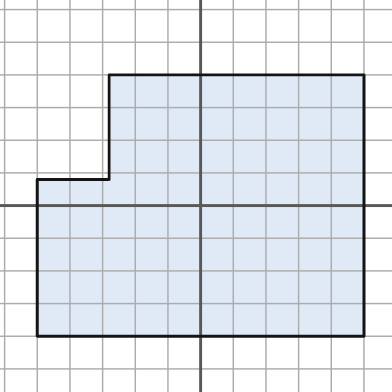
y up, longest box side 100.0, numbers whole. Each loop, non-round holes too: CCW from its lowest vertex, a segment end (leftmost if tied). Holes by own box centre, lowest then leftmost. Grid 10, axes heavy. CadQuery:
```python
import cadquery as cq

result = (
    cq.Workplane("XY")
    .moveTo(-50.0, -40.0)
    .lineTo(50.0, -40.0)
    .lineTo(50.0, 40.0)
    .lineTo(-28.0, 40.0)
    .lineTo(-28.0, 8.0)
    .lineTo(-50.0, 8.0)
    .close()
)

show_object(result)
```